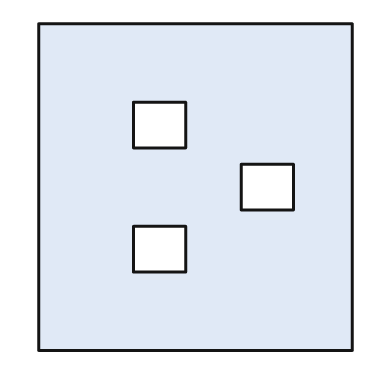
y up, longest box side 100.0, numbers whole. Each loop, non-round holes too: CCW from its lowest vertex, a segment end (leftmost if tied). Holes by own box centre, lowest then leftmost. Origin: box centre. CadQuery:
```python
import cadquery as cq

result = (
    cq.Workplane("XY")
    .moveTo(-48.0, -50.0)
    .lineTo(48.0, -50.0)
    .lineTo(48.0, 50.0)
    .lineTo(-48.0, 50.0)
    .close()
    .moveTo(-19.0, -26.0)
    .lineTo(-3.0, -26.0)
    .lineTo(-3.0, -12.0)
    .lineTo(-19.0, -12.0)
    .close()
    .moveTo(14.0, -7.0)
    .lineTo(30.0, -7.0)
    .lineTo(30.0, 7.0)
    .lineTo(14.0, 7.0)
    .close()
    .moveTo(-19.0, 12.0)
    .lineTo(-3.0, 12.0)
    .lineTo(-3.0, 26.0)
    .lineTo(-19.0, 26.0)
    .close()
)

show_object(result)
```